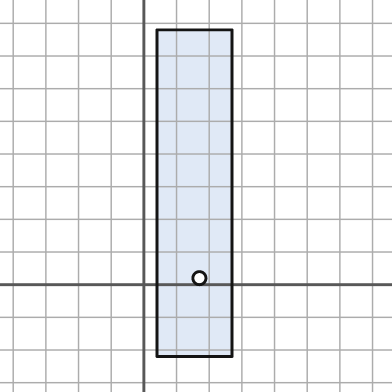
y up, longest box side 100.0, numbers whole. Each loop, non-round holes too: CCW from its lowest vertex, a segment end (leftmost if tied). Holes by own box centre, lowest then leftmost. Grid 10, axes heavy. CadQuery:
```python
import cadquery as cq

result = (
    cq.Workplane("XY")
    .moveTo(4.0, -22.0)
    .lineTo(27.0, -22.0)
    .lineTo(27.0, 78.0)
    .lineTo(4.0, 78.0)
    .close()
    .moveTo(17.0, 2.0)
    .circle(2.0)
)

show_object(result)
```